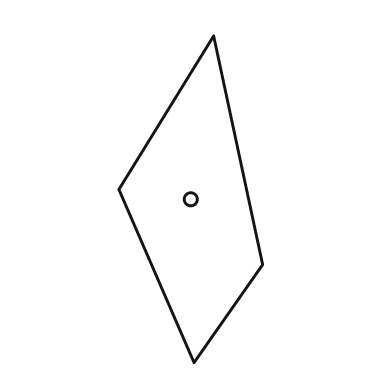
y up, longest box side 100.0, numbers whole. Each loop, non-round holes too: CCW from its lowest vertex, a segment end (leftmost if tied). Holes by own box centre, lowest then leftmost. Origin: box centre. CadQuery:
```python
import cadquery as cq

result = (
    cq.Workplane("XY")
    .moveTo(1.0, -50.0)
    .lineTo(22.0, -20.0)
    .lineTo(7.0, 50.0)
    .lineTo(-22.0, 3.0)
    .close()
    .moveTo(0.0, 0.0)
    .circle(2.0)
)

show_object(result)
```